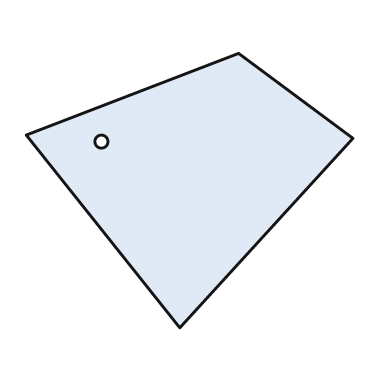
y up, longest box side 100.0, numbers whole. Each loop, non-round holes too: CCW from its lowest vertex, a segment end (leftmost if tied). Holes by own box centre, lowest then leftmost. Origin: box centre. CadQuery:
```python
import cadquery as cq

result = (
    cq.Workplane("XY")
    .moveTo(-3.0, -42.0)
    .lineTo(50.0, 16.0)
    .lineTo(15.0, 42.0)
    .lineTo(-50.0, 17.0)
    .close()
    .moveTo(-27.0, 15.0)
    .circle(2.0)
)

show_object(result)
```